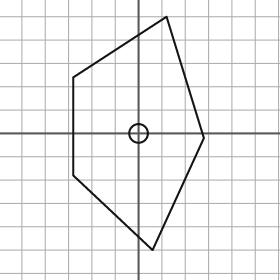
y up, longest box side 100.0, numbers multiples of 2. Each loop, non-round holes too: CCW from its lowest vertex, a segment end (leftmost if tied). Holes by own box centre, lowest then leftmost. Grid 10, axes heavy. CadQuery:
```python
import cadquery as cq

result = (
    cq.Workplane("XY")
    .moveTo(6.0, -50.0)
    .lineTo(28.0, -2.0)
    .lineTo(12.0, 50.0)
    .lineTo(-28.0, 24.0)
    .lineTo(-28.0, -18.0)
    .close()
    .moveTo(0.0, 0.0)
    .circle(4.0)
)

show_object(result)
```